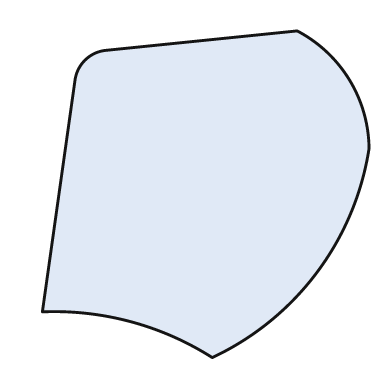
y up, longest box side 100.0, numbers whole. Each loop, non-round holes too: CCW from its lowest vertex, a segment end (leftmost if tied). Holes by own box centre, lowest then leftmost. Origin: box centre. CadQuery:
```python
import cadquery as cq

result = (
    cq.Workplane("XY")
    .moveTo(2.0, -50.0)
    .threePointArc((34.0, -24.0), (50.0, 14.0))
    .threePointArc((44.0, 35.0), (28.0, 50.0))
    .lineTo(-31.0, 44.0)
    .threePointArc((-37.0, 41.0), (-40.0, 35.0))
    .lineTo(-50.0, -36.0)
    .threePointArc((-23.0, -39.0), (2.0, -50.0))
    .close()
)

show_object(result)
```